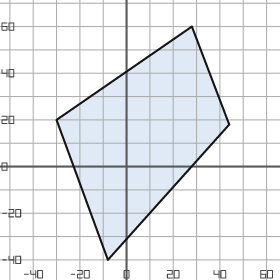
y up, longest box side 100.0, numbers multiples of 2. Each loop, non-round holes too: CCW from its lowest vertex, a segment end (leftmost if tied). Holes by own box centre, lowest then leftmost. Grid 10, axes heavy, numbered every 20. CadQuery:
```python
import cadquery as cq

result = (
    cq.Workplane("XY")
    .moveTo(-8.0, -40.0)
    .lineTo(44.0, 18.0)
    .lineTo(28.0, 60.0)
    .lineTo(-30.0, 20.0)
    .close()
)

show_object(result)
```